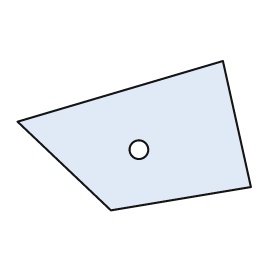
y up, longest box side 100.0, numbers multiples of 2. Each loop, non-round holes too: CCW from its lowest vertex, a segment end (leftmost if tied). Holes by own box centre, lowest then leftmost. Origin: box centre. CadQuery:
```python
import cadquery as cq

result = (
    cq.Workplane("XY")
    .moveTo(-10.0, -32.0)
    .lineTo(50.0, -22.0)
    .lineTo(38.0, 32.0)
    .lineTo(-50.0, 6.0)
    .close()
    .moveTo(2.0, -6.0)
    .circle(4.0)
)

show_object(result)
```